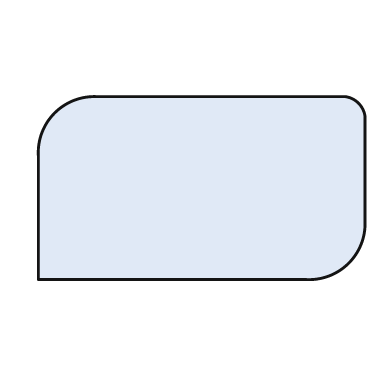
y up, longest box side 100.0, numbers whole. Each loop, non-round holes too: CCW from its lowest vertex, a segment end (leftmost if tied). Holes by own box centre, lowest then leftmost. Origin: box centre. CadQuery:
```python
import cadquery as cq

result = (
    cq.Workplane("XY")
    .moveTo(-50.0, -28.0)
    .lineTo(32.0, -28.0)
    .threePointArc((45.0, -23.0), (50.0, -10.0))
    .lineTo(50.0, 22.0)
    .threePointArc((48.0, 26.0), (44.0, 28.0))
    .lineTo(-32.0, 28.0)
    .threePointArc((-45.0, 23.0), (-50.0, 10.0))
    .close()
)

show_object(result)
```